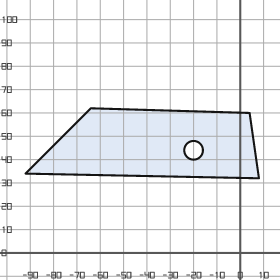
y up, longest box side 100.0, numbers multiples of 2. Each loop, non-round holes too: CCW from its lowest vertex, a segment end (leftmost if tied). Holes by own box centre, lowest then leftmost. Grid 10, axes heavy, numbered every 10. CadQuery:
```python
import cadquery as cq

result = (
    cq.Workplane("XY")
    .moveTo(8.0, 32.0)
    .lineTo(4.0, 60.0)
    .lineTo(-64.0, 62.0)
    .lineTo(-92.0, 34.0)
    .close()
    .moveTo(-20.0, 44.0)
    .circle(4.0)
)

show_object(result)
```